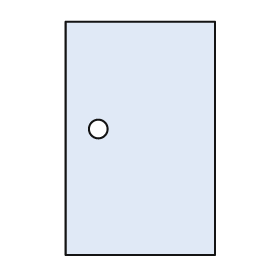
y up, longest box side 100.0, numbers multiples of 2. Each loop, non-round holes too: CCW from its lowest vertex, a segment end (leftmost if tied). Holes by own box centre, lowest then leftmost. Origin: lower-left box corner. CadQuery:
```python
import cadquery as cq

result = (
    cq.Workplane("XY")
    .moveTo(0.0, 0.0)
    .lineTo(64.0, 0.0)
    .lineTo(64.0, 100.0)
    .lineTo(0.0, 100.0)
    .close()
    .moveTo(14.0, 54.0)
    .circle(4.0)
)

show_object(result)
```